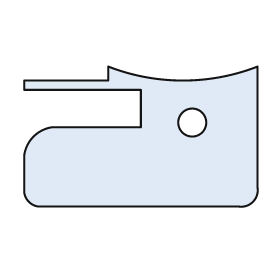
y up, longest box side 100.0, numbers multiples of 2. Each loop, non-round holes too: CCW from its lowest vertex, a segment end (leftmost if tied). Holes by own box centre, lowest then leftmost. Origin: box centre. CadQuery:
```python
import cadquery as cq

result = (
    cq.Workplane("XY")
    .moveTo(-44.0, -30.0)
    .lineTo(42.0, -30.0)
    .threePointArc((48.0, -28.0), (50.0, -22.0))
    .lineTo(50.0, 30.0)
    .threePointArc((18.0, 24.0), (-14.0, 30.0))
    .lineTo(-14.0, 24.0)
    .lineTo(-50.0, 24.0)
    .lineTo(-50.0, 20.0)
    .lineTo(0.0, 20.0)
    .lineTo(0.0, 4.0)
    .lineTo(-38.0, 4.0)
    .threePointArc((-46.0, 0.0), (-50.0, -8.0))
    .lineTo(-50.0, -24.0)
    .threePointArc((-48.0, -28.0), (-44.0, -30.0))
    .close()
    .moveTo(22.0, 6.0)
    .circle(6.0)
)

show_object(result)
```